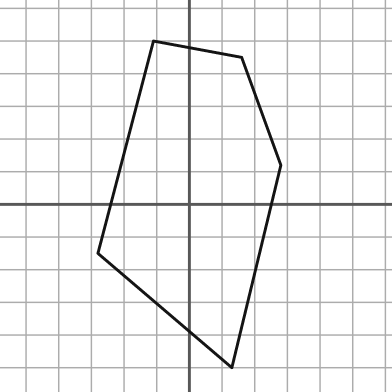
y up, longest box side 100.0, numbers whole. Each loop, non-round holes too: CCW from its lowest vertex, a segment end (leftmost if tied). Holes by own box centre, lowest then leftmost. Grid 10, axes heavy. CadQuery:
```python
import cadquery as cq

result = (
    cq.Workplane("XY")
    .moveTo(13.0, -50.0)
    .lineTo(28.0, 12.0)
    .lineTo(16.0, 45.0)
    .lineTo(-11.0, 50.0)
    .lineTo(-28.0, -15.0)
    .close()
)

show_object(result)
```